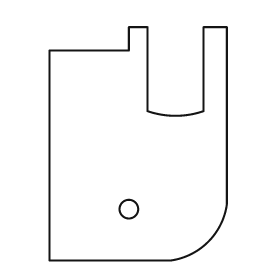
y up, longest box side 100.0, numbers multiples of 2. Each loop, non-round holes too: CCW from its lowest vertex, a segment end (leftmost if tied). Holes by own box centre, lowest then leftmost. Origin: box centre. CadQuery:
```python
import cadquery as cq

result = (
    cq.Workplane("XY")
    .moveTo(-38.0, -50.0)
    .lineTo(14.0, -50.0)
    .threePointArc((30.0, -42.0), (38.0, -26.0))
    .lineTo(38.0, 50.0)
    .lineTo(28.0, 50.0)
    .lineTo(28.0, 14.0)
    .threePointArc((16.0, 12.0), (4.0, 14.0))
    .lineTo(4.0, 50.0)
    .lineTo(-4.0, 50.0)
    .lineTo(-4.0, 40.0)
    .lineTo(-38.0, 40.0)
    .close()
    .moveTo(-4.0, -28.0)
    .circle(4.0)
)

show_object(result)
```